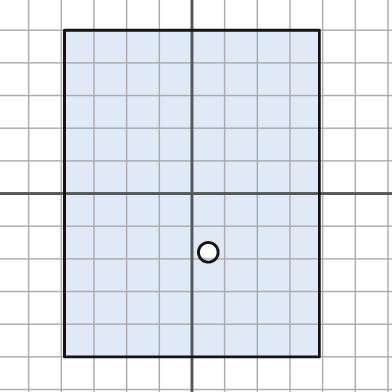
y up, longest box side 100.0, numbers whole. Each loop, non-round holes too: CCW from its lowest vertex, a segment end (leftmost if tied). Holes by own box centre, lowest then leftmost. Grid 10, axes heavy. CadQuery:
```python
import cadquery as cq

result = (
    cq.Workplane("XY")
    .moveTo(-39.0, -50.0)
    .lineTo(39.0, -50.0)
    .lineTo(39.0, 50.0)
    .lineTo(-39.0, 50.0)
    .close()
    .moveTo(5.0, -18.0)
    .circle(3.0)
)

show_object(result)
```